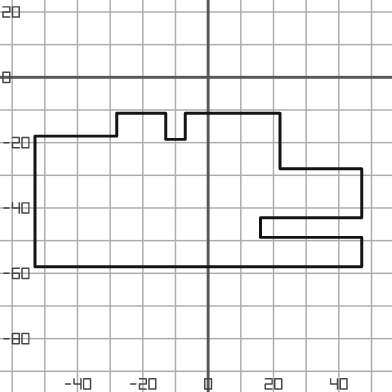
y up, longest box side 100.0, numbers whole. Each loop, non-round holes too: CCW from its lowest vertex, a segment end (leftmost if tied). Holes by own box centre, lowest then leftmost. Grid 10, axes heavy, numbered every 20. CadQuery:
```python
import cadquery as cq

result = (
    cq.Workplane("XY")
    .moveTo(-53.0, -58.0)
    .lineTo(47.0, -58.0)
    .lineTo(47.0, -49.0)
    .lineTo(16.0, -49.0)
    .lineTo(16.0, -43.0)
    .lineTo(47.0, -43.0)
    .lineTo(47.0, -28.0)
    .lineTo(22.0, -28.0)
    .lineTo(22.0, -11.0)
    .lineTo(-7.0, -11.0)
    .lineTo(-7.0, -19.0)
    .lineTo(-13.0, -19.0)
    .lineTo(-13.0, -11.0)
    .lineTo(-28.0, -11.0)
    .lineTo(-28.0, -18.0)
    .lineTo(-53.0, -18.0)
    .close()
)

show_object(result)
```